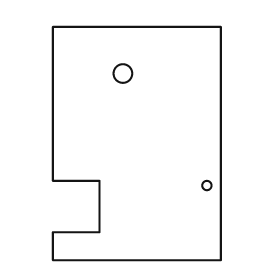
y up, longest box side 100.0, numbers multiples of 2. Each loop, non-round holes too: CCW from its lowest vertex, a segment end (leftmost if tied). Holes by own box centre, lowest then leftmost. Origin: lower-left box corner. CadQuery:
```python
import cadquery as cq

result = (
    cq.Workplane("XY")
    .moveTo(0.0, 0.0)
    .lineTo(72.0, 0.0)
    .lineTo(72.0, 100.0)
    .lineTo(0.0, 100.0)
    .lineTo(0.0, 34.0)
    .lineTo(20.0, 34.0)
    .lineTo(20.0, 12.0)
    .lineTo(0.0, 12.0)
    .close()
    .moveTo(66.0, 32.0)
    .circle(2.0)
    .moveTo(30.0, 80.0)
    .circle(4.0)
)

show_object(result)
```